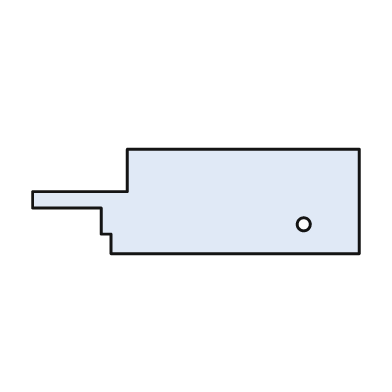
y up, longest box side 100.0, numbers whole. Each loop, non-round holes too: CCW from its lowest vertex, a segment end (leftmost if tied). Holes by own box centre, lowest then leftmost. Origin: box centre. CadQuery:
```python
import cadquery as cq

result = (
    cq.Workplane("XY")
    .moveTo(-26.0, -16.0)
    .lineTo(50.0, -16.0)
    .lineTo(50.0, 16.0)
    .lineTo(-21.0, 16.0)
    .lineTo(-21.0, 3.0)
    .lineTo(-50.0, 3.0)
    .lineTo(-50.0, -2.0)
    .lineTo(-29.0, -2.0)
    .lineTo(-29.0, -10.0)
    .lineTo(-26.0, -10.0)
    .close()
    .moveTo(33.0, -7.0)
    .circle(2.0)
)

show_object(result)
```